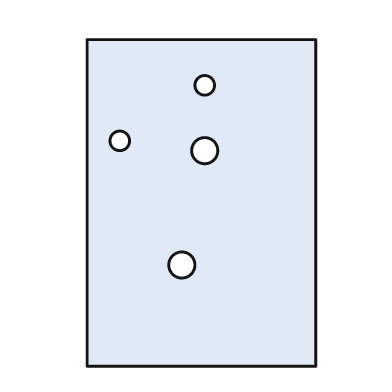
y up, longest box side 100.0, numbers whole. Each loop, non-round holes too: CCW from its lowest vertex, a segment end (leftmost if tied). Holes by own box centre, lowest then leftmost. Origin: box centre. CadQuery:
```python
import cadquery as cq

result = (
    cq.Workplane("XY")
    .moveTo(-35.0, -50.0)
    .lineTo(35.0, -50.0)
    .lineTo(35.0, 50.0)
    .lineTo(-35.0, 50.0)
    .close()
    .moveTo(-6.0, -19.0)
    .circle(4.0)
    .moveTo(1.0, 16.0)
    .circle(4.0)
    .moveTo(-25.0, 19.0)
    .circle(3.0)
    .moveTo(1.0, 36.0)
    .circle(3.0)
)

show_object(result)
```